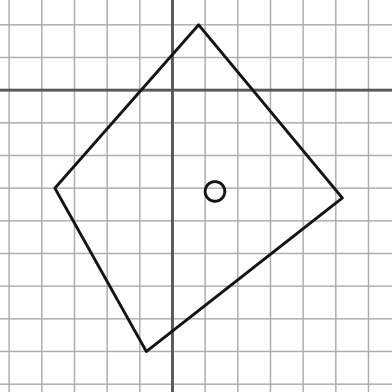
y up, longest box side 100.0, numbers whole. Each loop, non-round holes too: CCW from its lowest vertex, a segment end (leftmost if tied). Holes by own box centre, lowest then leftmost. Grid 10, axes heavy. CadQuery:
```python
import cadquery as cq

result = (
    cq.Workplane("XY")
    .moveTo(-8.0, -80.0)
    .lineTo(52.0, -33.0)
    .lineTo(8.0, 20.0)
    .lineTo(-36.0, -30.0)
    .close()
    .moveTo(13.0, -31.0)
    .circle(3.0)
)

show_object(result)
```